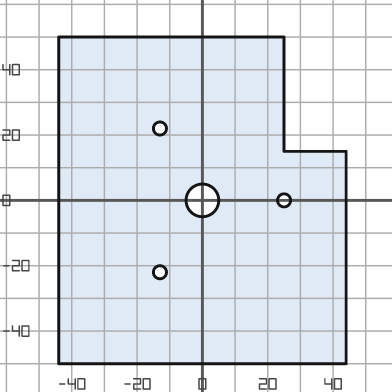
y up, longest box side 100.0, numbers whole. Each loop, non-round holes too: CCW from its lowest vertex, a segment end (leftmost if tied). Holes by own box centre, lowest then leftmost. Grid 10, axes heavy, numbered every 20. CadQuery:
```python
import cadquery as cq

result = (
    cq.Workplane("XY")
    .moveTo(-44.0, -50.0)
    .lineTo(44.0, -50.0)
    .lineTo(44.0, 15.0)
    .lineTo(25.0, 15.0)
    .lineTo(25.0, 50.0)
    .lineTo(-44.0, 50.0)
    .close()
    .moveTo(-13.0, -22.0)
    .circle(2.0)
    .moveTo(0.0, 0.0)
    .circle(5.0)
    .moveTo(25.0, 0.0)
    .circle(2.0)
    .moveTo(-13.0, 22.0)
    .circle(2.0)
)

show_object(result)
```